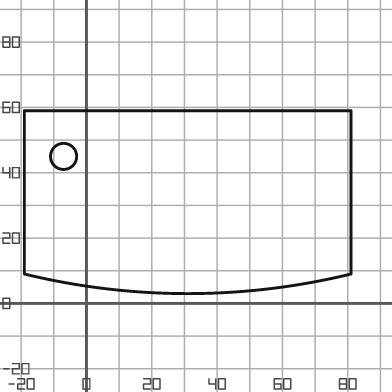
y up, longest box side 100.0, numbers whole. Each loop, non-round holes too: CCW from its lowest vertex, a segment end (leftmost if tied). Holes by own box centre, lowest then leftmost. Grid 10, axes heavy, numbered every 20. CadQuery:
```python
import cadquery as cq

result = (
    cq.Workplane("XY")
    .moveTo(-19.0, 9.0)
    .threePointArc((31.0, 3.0), (81.0, 9.0))
    .lineTo(81.0, 59.0)
    .lineTo(-19.0, 59.0)
    .close()
    .moveTo(-7.0, 45.0)
    .circle(4.0)
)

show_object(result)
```